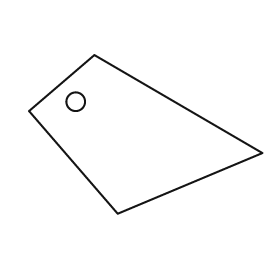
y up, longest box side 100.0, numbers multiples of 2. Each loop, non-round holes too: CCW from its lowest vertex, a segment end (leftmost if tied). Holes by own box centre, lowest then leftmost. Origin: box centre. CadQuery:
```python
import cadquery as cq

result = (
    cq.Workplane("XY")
    .moveTo(-12.0, -34.0)
    .lineTo(50.0, -8.0)
    .lineTo(-22.0, 34.0)
    .lineTo(-50.0, 10.0)
    .close()
    .moveTo(-30.0, 14.0)
    .circle(4.0)
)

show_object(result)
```